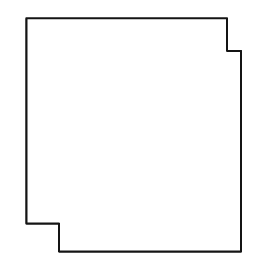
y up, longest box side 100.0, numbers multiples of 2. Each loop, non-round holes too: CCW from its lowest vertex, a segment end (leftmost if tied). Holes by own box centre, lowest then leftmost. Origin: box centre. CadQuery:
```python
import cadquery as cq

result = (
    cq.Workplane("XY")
    .moveTo(-32.0, -50.0)
    .lineTo(46.0, -50.0)
    .lineTo(46.0, 36.0)
    .lineTo(40.0, 36.0)
    .lineTo(40.0, 50.0)
    .lineTo(-46.0, 50.0)
    .lineTo(-46.0, -38.0)
    .lineTo(-32.0, -38.0)
    .close()
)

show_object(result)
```